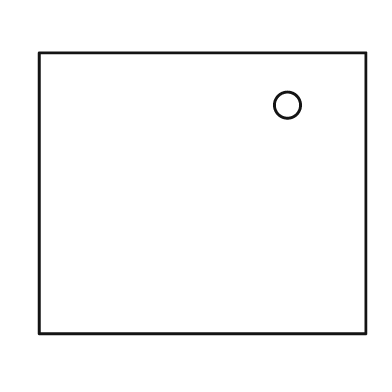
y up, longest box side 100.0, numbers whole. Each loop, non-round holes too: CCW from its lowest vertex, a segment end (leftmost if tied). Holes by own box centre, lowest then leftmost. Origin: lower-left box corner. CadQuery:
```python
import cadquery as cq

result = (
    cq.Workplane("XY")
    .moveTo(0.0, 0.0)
    .lineTo(100.0, 0.0)
    .lineTo(100.0, 86.0)
    .lineTo(0.0, 86.0)
    .close()
    .moveTo(76.0, 70.0)
    .circle(4.0)
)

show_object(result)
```